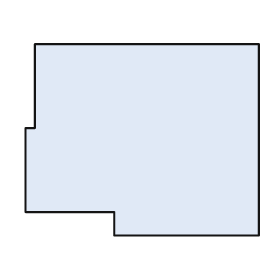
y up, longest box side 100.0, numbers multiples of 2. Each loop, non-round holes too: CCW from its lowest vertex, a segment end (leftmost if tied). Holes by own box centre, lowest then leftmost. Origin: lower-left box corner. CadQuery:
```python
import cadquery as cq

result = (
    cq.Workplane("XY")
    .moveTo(38.0, 0.0)
    .lineTo(100.0, 0.0)
    .lineTo(100.0, 82.0)
    .lineTo(4.0, 82.0)
    .lineTo(4.0, 46.0)
    .lineTo(0.0, 46.0)
    .lineTo(0.0, 10.0)
    .lineTo(38.0, 10.0)
    .close()
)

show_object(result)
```